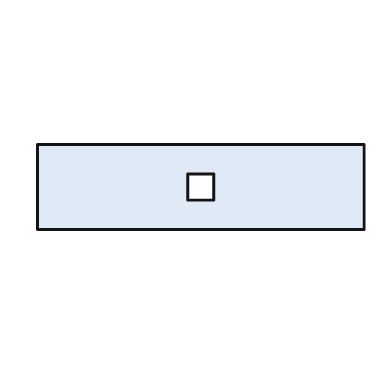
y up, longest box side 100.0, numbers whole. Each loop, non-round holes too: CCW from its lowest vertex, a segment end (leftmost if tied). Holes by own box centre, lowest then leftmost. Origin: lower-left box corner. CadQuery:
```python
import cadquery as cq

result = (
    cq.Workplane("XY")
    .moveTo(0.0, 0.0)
    .lineTo(100.0, 0.0)
    .lineTo(100.0, 26.0)
    .lineTo(0.0, 26.0)
    .close()
    .moveTo(46.0, 9.0)
    .lineTo(54.0, 9.0)
    .lineTo(54.0, 17.0)
    .lineTo(46.0, 17.0)
    .close()
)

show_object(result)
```